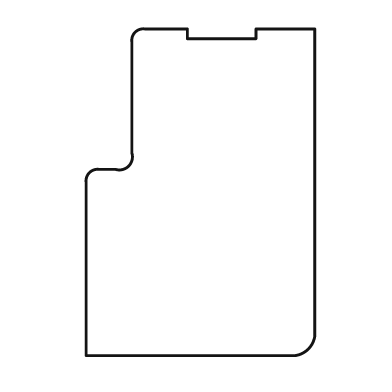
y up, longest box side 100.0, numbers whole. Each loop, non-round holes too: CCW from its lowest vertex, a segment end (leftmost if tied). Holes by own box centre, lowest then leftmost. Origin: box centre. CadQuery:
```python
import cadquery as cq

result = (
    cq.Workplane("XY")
    .moveTo(-35.0, -50.0)
    .lineTo(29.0, -50.0)
    .threePointArc((33.0, -48.0), (35.0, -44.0))
    .lineTo(35.0, 50.0)
    .lineTo(17.0, 50.0)
    .lineTo(17.0, 47.0)
    .lineTo(-4.0, 47.0)
    .lineTo(-4.0, 50.0)
    .lineTo(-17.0, 50.0)
    .threePointArc((-20.0, 49.0), (-21.0, 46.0))
    .lineTo(-21.0, 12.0)
    .threePointArc((-22.0, 8.0), (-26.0, 7.0))
    .lineTo(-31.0, 7.0)
    .threePointArc((-34.0, 6.0), (-35.0, 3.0))
    .close()
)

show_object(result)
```